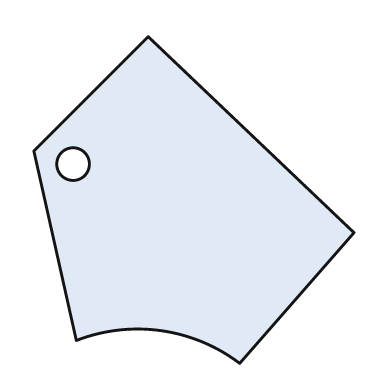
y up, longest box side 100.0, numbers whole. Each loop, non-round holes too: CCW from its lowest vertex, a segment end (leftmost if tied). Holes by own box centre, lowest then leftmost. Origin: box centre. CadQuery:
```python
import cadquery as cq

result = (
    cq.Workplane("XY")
    .moveTo(14.0, -50.0)
    .lineTo(49.0, -10.0)
    .lineTo(-14.0, 50.0)
    .lineTo(-49.0, 15.0)
    .lineTo(-36.0, -43.0)
    .threePointArc((-10.0, -40.0), (14.0, -50.0))
    .close()
    .moveTo(-37.0, 11.0)
    .circle(5.0)
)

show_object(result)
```